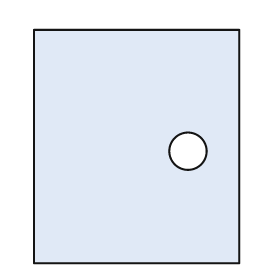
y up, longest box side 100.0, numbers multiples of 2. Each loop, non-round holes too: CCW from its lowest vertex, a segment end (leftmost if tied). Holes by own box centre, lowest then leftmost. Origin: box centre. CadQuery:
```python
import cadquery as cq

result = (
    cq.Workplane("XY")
    .moveTo(-44.0, -50.0)
    .lineTo(44.0, -50.0)
    .lineTo(44.0, 50.0)
    .lineTo(-44.0, 50.0)
    .close()
    .moveTo(22.0, -2.0)
    .circle(8.0)
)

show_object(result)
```